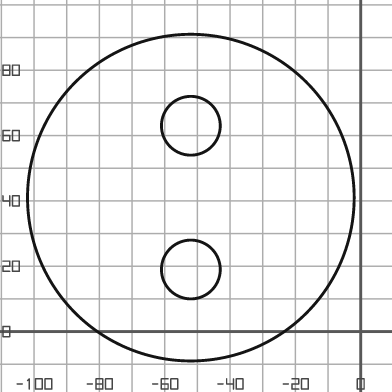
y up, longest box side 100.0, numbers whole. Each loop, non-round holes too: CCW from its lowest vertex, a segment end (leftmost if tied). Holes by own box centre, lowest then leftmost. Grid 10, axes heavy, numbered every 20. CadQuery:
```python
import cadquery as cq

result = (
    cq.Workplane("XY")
    .moveTo(-52.0, 41.0)
    .circle(50.0)
    .moveTo(-52.0, 19.0)
    .circle(9.0)
    .moveTo(-52.0, 63.0)
    .circle(9.0)
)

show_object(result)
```